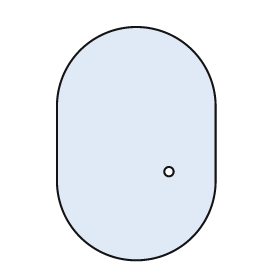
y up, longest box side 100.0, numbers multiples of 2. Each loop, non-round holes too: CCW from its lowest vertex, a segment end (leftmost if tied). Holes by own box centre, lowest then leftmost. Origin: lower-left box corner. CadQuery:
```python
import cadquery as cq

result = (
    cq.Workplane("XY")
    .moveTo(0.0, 34.0)
    .threePointArc((34.0, 0.0), (68.0, 34.0))
    .lineTo(68.0, 66.0)
    .threePointArc((34.0, 100.0), (0.0, 66.0))
    .close()
    .moveTo(48.0, 38.0)
    .circle(2.0)
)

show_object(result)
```